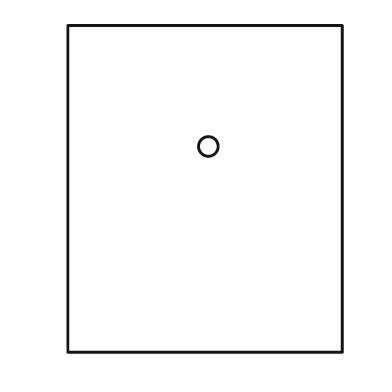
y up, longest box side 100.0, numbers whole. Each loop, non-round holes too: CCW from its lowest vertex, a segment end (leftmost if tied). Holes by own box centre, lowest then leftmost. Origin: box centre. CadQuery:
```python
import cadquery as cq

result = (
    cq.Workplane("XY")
    .moveTo(-42.0, -50.0)
    .lineTo(42.0, -50.0)
    .lineTo(42.0, 50.0)
    .lineTo(-42.0, 50.0)
    .close()
    .moveTo(1.0, 13.0)
    .circle(3.0)
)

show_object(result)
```